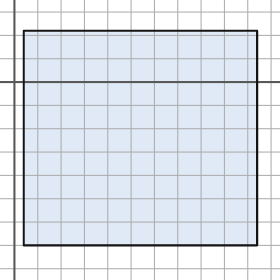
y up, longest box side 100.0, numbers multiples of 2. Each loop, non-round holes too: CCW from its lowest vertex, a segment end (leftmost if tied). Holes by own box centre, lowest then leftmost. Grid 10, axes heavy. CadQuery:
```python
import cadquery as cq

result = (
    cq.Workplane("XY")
    .moveTo(4.0, -70.0)
    .lineTo(104.0, -70.0)
    .lineTo(104.0, 22.0)
    .lineTo(4.0, 22.0)
    .close()
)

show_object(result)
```